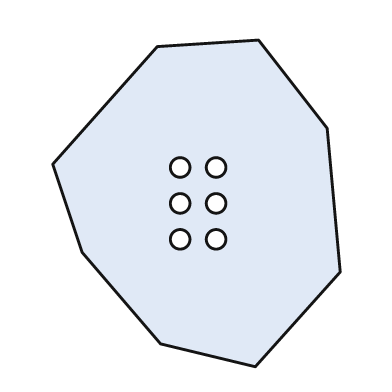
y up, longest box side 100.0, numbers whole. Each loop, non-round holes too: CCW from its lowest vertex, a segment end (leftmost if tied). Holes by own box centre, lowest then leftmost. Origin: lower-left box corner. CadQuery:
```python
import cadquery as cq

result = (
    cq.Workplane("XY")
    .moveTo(62.0, 0.0)
    .lineTo(88.0, 29.0)
    .lineTo(84.0, 73.0)
    .lineTo(63.0, 100.0)
    .lineTo(32.0, 98.0)
    .lineTo(0.0, 62.0)
    .lineTo(9.0, 35.0)
    .lineTo(33.0, 7.0)
    .close()
    .moveTo(39.0, 39.0)
    .circle(3.0)
    .moveTo(50.0, 39.0)
    .circle(3.0)
    .moveTo(39.0, 50.0)
    .circle(3.0)
    .moveTo(50.0, 50.0)
    .circle(3.0)
    .moveTo(39.0, 61.0)
    .circle(3.0)
    .moveTo(50.0, 61.0)
    .circle(3.0)
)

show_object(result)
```